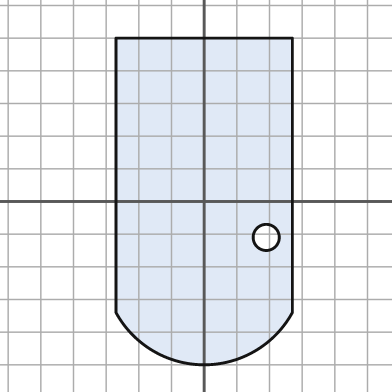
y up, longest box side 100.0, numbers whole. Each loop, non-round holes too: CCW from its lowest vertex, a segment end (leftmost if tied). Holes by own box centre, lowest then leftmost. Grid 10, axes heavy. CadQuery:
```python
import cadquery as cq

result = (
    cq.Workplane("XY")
    .moveTo(-27.0, -34.0)
    .threePointArc((0.0, -50.0), (27.0, -34.0))
    .lineTo(27.0, 50.0)
    .lineTo(-27.0, 50.0)
    .close()
    .moveTo(19.0, -11.0)
    .circle(4.0)
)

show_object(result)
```